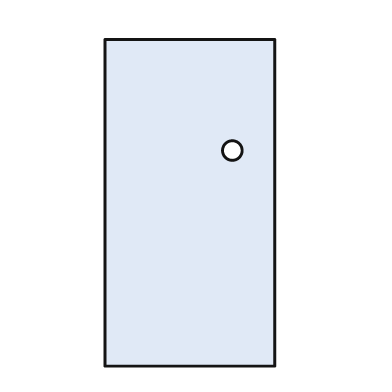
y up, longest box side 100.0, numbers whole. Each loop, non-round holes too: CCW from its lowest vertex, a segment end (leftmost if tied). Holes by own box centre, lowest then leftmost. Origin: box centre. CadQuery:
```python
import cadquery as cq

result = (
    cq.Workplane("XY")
    .moveTo(-26.0, -50.0)
    .lineTo(26.0, -50.0)
    .lineTo(26.0, 50.0)
    .lineTo(-26.0, 50.0)
    .close()
    .moveTo(13.0, 16.0)
    .circle(3.0)
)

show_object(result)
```